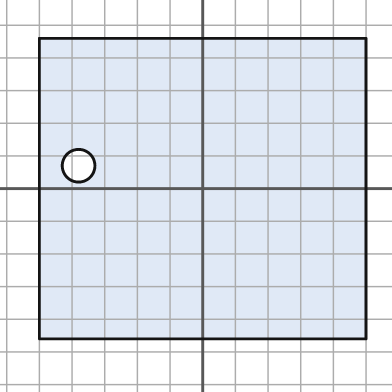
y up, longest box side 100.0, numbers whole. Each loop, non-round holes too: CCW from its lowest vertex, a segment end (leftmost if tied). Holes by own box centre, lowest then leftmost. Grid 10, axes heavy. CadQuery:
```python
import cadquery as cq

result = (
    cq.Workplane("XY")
    .moveTo(-50.0, -46.0)
    .lineTo(50.0, -46.0)
    .lineTo(50.0, 46.0)
    .lineTo(-50.0, 46.0)
    .close()
    .moveTo(-38.0, 7.0)
    .circle(5.0)
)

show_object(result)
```